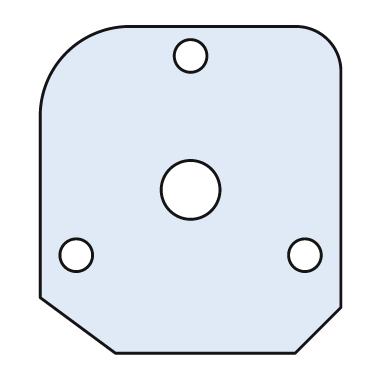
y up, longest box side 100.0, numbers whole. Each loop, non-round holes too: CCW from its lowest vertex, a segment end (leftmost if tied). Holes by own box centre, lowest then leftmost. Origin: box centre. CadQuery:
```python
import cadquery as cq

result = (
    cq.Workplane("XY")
    .moveTo(-23.0, -50.0)
    .lineTo(32.0, -50.0)
    .lineTo(46.0, -36.0)
    .lineTo(46.0, 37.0)
    .threePointArc((42.0, 46.0), (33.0, 50.0))
    .lineTo(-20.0, 50.0)
    .threePointArc((-38.0, 42.0), (-46.0, 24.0))
    .lineTo(-46.0, -33.0)
    .close()
    .moveTo(-35.0, -20.0)
    .circle(5.0)
    .moveTo(35.0, -20.0)
    .circle(5.0)
    .moveTo(0.0, 0.0)
    .circle(9.0)
    .moveTo(0.0, 41.0)
    .circle(5.0)
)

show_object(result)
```